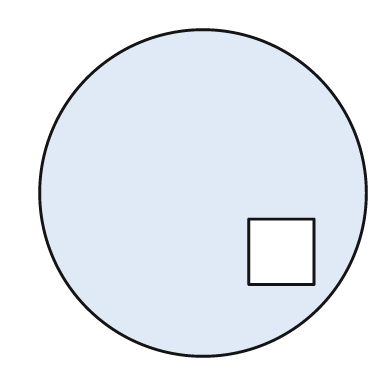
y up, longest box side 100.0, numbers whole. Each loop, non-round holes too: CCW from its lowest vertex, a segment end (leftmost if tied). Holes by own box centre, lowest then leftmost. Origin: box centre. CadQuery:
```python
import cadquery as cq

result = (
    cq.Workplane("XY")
    .moveTo(0.0, 0.0)
    .circle(50.0)
    .moveTo(14.0, -28.0)
    .lineTo(34.0, -28.0)
    .lineTo(34.0, -8.0)
    .lineTo(14.0, -8.0)
    .close()
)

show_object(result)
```